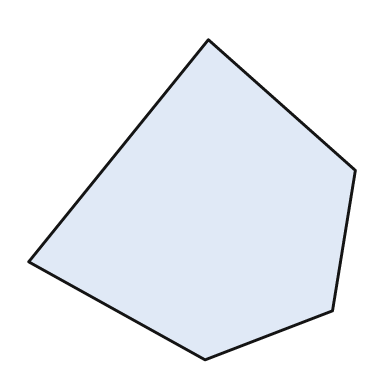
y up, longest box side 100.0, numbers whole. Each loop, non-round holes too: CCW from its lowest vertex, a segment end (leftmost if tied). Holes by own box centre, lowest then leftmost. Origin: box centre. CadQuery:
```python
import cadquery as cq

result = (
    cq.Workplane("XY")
    .moveTo(4.0, -49.0)
    .lineTo(43.0, -34.0)
    .lineTo(50.0, 9.0)
    .lineTo(5.0, 49.0)
    .lineTo(-50.0, -19.0)
    .close()
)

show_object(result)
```